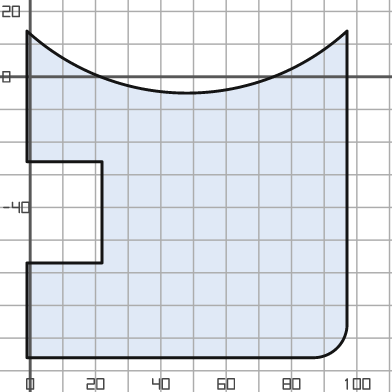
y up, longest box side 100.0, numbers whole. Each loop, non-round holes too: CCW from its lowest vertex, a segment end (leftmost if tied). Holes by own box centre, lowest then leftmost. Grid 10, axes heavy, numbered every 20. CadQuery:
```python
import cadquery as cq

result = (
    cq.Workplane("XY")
    .moveTo(-1.0, -86.0)
    .lineTo(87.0, -86.0)
    .threePointArc((94.0, -83.0), (97.0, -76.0))
    .lineTo(97.0, 14.0)
    .threePointArc((48.0, -5.0), (-1.0, 14.0))
    .lineTo(-1.0, -26.0)
    .lineTo(22.0, -26.0)
    .lineTo(22.0, -57.0)
    .lineTo(-1.0, -57.0)
    .close()
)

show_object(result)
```